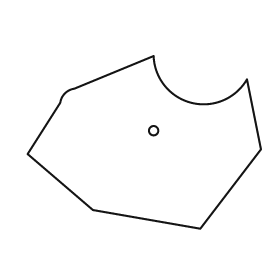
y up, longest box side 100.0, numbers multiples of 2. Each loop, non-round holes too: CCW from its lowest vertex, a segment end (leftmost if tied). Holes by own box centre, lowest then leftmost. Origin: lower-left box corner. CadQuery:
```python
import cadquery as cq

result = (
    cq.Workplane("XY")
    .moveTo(74.0, 0.0)
    .lineTo(100.0, 34.0)
    .lineTo(94.0, 64.0)
    .threePointArc((70.0, 54.0), (54.0, 74.0))
    .lineTo(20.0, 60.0)
    .threePointArc((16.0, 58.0), (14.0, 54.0))
    .lineTo(0.0, 32.0)
    .lineTo(28.0, 8.0)
    .close()
    .moveTo(54.0, 42.0)
    .circle(2.0)
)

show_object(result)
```